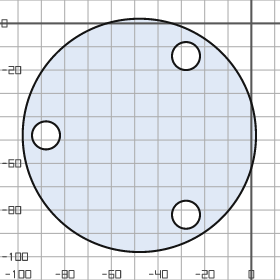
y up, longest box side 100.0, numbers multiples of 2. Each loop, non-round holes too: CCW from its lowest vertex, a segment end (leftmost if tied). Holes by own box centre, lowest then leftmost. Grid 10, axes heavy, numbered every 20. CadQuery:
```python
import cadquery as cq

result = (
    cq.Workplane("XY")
    .moveTo(-48.0, -48.0)
    .circle(50.0)
    .moveTo(-28.0, -82.0)
    .circle(6.0)
    .moveTo(-88.0, -48.0)
    .circle(6.0)
    .moveTo(-28.0, -14.0)
    .circle(6.0)
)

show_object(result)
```